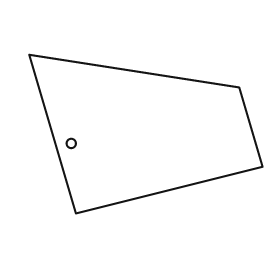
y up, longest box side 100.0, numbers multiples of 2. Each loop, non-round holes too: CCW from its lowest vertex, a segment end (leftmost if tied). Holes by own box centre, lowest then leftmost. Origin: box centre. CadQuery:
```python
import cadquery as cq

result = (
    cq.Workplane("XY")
    .moveTo(-30.0, -34.0)
    .lineTo(50.0, -14.0)
    .lineTo(40.0, 20.0)
    .lineTo(-50.0, 34.0)
    .close()
    .moveTo(-32.0, -4.0)
    .circle(2.0)
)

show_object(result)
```